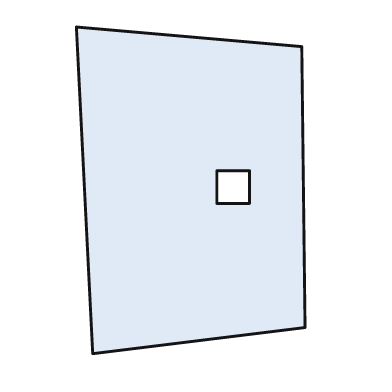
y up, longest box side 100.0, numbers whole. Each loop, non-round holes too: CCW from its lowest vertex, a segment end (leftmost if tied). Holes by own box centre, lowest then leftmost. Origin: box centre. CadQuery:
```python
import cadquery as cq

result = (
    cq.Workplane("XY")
    .moveTo(-30.0, -50.0)
    .lineTo(35.0, -42.0)
    .lineTo(34.0, 44.0)
    .lineTo(-35.0, 50.0)
    .close()
    .moveTo(8.0, -4.0)
    .lineTo(18.0, -4.0)
    .lineTo(18.0, 6.0)
    .lineTo(8.0, 6.0)
    .close()
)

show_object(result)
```